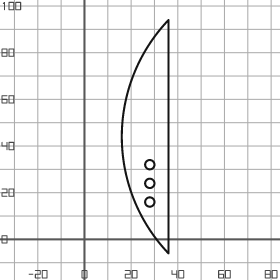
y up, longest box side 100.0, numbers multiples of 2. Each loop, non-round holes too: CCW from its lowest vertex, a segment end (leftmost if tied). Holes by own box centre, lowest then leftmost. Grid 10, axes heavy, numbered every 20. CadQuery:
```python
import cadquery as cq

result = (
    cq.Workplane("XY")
    .moveTo(36.0, -6.0)
    .lineTo(36.0, 94.0)
    .threePointArc((16.0, 44.0), (36.0, -6.0))
    .close()
    .moveTo(28.0, 16.0)
    .circle(2.0)
    .moveTo(28.0, 24.0)
    .circle(2.0)
    .moveTo(28.0, 32.0)
    .circle(2.0)
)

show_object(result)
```